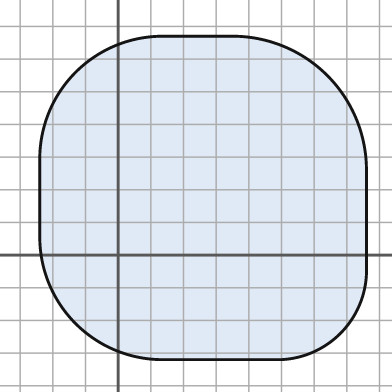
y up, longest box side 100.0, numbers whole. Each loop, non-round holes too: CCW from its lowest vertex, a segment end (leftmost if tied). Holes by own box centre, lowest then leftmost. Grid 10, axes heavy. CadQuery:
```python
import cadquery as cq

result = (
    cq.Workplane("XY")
    .moveTo(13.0, -32.0)
    .lineTo(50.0, -32.0)
    .threePointArc((68.0, -24.0), (76.0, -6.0))
    .lineTo(76.0, 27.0)
    .threePointArc((64.0, 55.0), (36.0, 67.0))
    .lineTo(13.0, 67.0)
    .threePointArc((-13.0, 56.0), (-24.0, 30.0))
    .lineTo(-24.0, 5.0)
    .threePointArc((-13.0, -21.0), (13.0, -32.0))
    .close()
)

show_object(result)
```